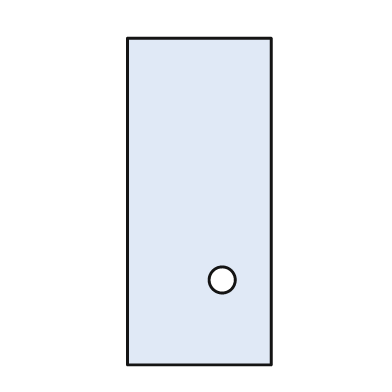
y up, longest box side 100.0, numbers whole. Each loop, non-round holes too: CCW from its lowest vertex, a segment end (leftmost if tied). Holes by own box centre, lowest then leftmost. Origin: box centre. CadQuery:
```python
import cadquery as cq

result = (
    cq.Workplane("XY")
    .moveTo(-22.0, -50.0)
    .lineTo(22.0, -50.0)
    .lineTo(22.0, 50.0)
    .lineTo(-22.0, 50.0)
    .close()
    .moveTo(7.0, -24.0)
    .circle(4.0)
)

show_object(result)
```